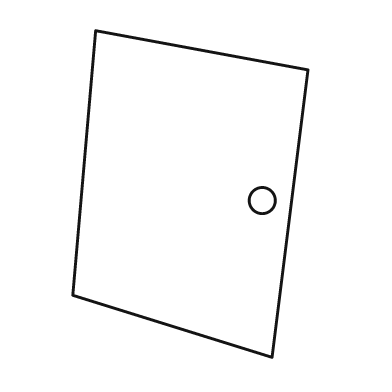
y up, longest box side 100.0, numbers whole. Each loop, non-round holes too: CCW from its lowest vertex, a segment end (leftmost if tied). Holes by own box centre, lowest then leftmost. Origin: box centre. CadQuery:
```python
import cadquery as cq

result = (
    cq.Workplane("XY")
    .moveTo(25.0, -50.0)
    .lineTo(36.0, 38.0)
    .lineTo(-29.0, 50.0)
    .lineTo(-36.0, -31.0)
    .close()
    .moveTo(22.0, -2.0)
    .circle(4.0)
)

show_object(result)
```